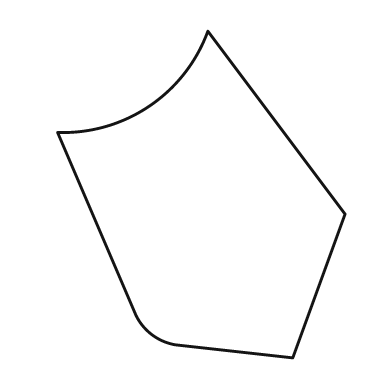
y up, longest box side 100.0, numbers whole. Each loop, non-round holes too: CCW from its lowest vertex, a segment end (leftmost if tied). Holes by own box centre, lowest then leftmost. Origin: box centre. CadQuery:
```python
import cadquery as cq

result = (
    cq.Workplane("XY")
    .moveTo(28.0, -50.0)
    .lineTo(44.0, -6.0)
    .lineTo(2.0, 50.0)
    .threePointArc((-16.0, 27.0), (-44.0, 19.0))
    .lineTo(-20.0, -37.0)
    .threePointArc((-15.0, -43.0), (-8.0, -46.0))
    .close()
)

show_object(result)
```